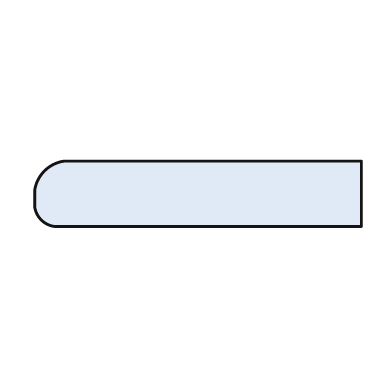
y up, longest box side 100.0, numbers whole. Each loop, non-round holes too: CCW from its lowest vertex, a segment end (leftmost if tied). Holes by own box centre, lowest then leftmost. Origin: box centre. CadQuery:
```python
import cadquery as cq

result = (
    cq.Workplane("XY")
    .moveTo(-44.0, -10.0)
    .lineTo(50.0, -10.0)
    .lineTo(50.0, 10.0)
    .lineTo(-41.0, 10.0)
    .threePointArc((-47.0, 7.0), (-50.0, 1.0))
    .lineTo(-50.0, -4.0)
    .threePointArc((-48.0, -8.0), (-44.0, -10.0))
    .close()
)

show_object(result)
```